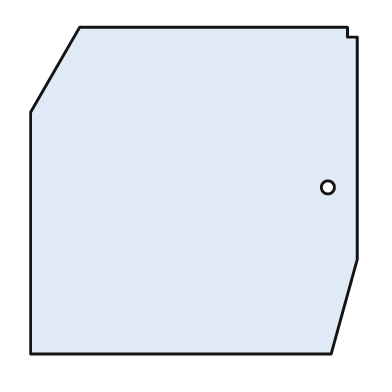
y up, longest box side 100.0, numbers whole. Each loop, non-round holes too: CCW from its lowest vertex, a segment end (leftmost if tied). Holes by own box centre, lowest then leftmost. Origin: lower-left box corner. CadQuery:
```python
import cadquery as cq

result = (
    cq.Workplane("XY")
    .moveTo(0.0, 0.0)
    .lineTo(92.0, 0.0)
    .lineTo(100.0, 29.0)
    .lineTo(100.0, 97.0)
    .lineTo(97.0, 97.0)
    .lineTo(97.0, 100.0)
    .lineTo(15.0, 100.0)
    .lineTo(0.0, 74.0)
    .close()
    .moveTo(91.0, 51.0)
    .circle(2.0)
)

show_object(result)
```